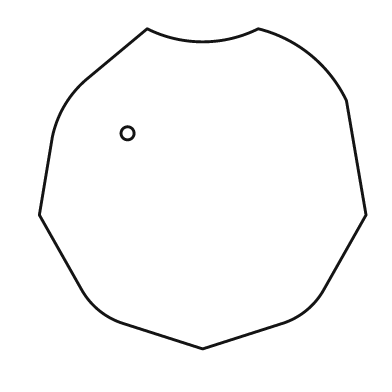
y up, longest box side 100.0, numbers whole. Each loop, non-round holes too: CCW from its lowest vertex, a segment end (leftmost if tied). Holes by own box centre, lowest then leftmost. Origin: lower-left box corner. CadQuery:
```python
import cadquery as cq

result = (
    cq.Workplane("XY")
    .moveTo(50.0, 0.0)
    .lineTo(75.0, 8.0)
    .threePointArc((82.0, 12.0), (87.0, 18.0))
    .lineTo(100.0, 41.0)
    .lineTo(94.0, 76.0)
    .threePointArc((83.0, 90.0), (67.0, 98.0))
    .threePointArc((50.0, 94.0), (33.0, 98.0))
    .lineTo(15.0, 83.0)
    .threePointArc((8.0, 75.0), (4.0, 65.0))
    .lineTo(0.0, 41.0)
    .lineTo(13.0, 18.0)
    .threePointArc((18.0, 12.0), (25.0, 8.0))
    .close()
    .moveTo(27.0, 66.0)
    .circle(2.0)
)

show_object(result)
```